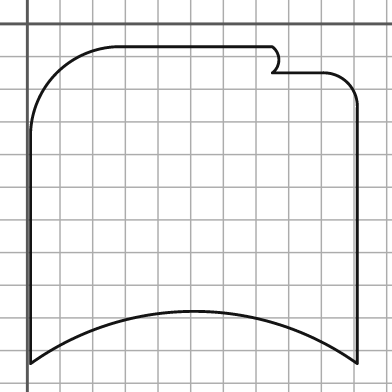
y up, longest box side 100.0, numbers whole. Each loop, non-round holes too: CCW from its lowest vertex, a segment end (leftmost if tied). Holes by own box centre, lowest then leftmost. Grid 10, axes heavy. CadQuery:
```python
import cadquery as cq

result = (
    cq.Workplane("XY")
    .moveTo(1.0, -104.0)
    .threePointArc((51.0, -88.0), (101.0, -104.0))
    .lineTo(101.0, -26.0)
    .threePointArc((98.0, -18.0), (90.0, -15.0))
    .lineTo(75.0, -15.0)
    .threePointArc((77.0, -11.0), (75.0, -7.0))
    .lineTo(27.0, -7.0)
    .threePointArc((9.0, -15.0), (1.0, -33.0))
    .close()
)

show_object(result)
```